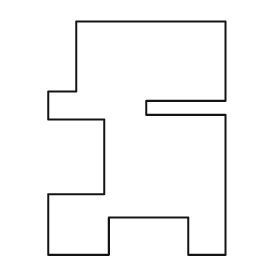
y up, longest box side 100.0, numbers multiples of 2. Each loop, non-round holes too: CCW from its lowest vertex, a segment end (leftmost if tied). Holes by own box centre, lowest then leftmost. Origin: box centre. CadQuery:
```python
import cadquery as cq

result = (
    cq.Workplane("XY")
    .moveTo(-38.0, -50.0)
    .lineTo(-12.0, -50.0)
    .lineTo(-12.0, -34.0)
    .lineTo(22.0, -34.0)
    .lineTo(22.0, -50.0)
    .lineTo(38.0, -50.0)
    .lineTo(38.0, 10.0)
    .lineTo(4.0, 10.0)
    .lineTo(4.0, 16.0)
    .lineTo(38.0, 16.0)
    .lineTo(38.0, 50.0)
    .lineTo(-26.0, 50.0)
    .lineTo(-26.0, 20.0)
    .lineTo(-38.0, 20.0)
    .lineTo(-38.0, 8.0)
    .lineTo(-14.0, 8.0)
    .lineTo(-14.0, -24.0)
    .lineTo(-38.0, -24.0)
    .close()
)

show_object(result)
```